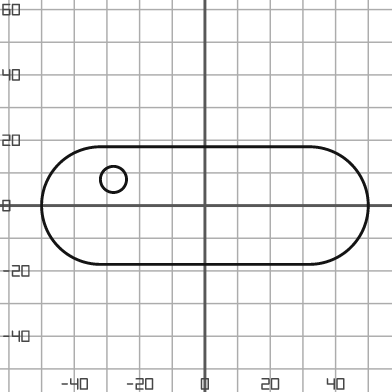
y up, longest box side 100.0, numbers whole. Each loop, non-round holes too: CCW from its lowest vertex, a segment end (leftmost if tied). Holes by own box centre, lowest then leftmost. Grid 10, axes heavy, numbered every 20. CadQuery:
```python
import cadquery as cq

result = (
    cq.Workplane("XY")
    .moveTo(-32.0, -18.0)
    .lineTo(32.0, -18.0)
    .threePointArc((50.0, 0.0), (32.0, 18.0))
    .lineTo(-32.0, 18.0)
    .threePointArc((-50.0, 0.0), (-32.0, -18.0))
    .close()
    .moveTo(-28.0, 8.0)
    .circle(4.0)
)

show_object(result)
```